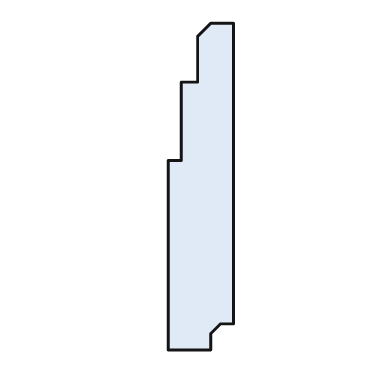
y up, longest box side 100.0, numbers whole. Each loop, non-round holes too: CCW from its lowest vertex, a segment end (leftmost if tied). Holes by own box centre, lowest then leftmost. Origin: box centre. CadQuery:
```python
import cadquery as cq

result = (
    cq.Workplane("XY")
    .moveTo(-10.0, -50.0)
    .lineTo(3.0, -50.0)
    .lineTo(3.0, -45.0)
    .lineTo(6.0, -42.0)
    .lineTo(10.0, -42.0)
    .lineTo(10.0, 50.0)
    .lineTo(3.0, 50.0)
    .lineTo(-1.0, 46.0)
    .lineTo(-1.0, 32.0)
    .lineTo(-6.0, 32.0)
    .lineTo(-6.0, 8.0)
    .lineTo(-10.0, 8.0)
    .close()
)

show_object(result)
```